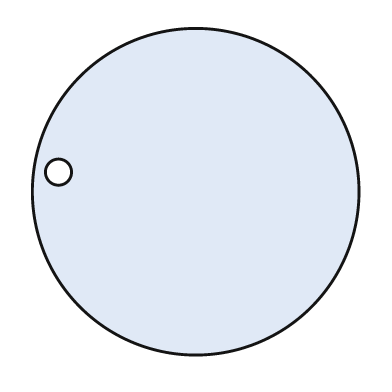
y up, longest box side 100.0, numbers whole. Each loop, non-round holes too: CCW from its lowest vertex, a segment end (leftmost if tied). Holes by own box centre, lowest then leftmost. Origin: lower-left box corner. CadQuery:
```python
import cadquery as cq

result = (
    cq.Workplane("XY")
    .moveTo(50.0, 50.0)
    .circle(50.0)
    .moveTo(8.0, 56.0)
    .circle(4.0)
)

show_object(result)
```